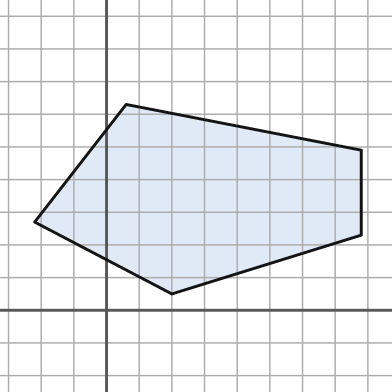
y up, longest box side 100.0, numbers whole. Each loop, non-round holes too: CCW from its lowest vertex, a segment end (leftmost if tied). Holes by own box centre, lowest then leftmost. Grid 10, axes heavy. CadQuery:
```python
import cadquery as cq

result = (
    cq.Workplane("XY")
    .moveTo(20.0, 5.0)
    .lineTo(78.0, 23.0)
    .lineTo(78.0, 49.0)
    .lineTo(6.0, 63.0)
    .lineTo(-22.0, 27.0)
    .close()
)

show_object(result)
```